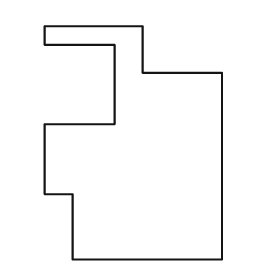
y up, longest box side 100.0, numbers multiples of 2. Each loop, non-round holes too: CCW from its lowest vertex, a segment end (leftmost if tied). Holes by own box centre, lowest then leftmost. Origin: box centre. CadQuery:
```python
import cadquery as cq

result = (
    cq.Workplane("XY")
    .moveTo(-26.0, -50.0)
    .lineTo(38.0, -50.0)
    .lineTo(38.0, 30.0)
    .lineTo(4.0, 30.0)
    .lineTo(4.0, 50.0)
    .lineTo(-38.0, 50.0)
    .lineTo(-38.0, 42.0)
    .lineTo(-8.0, 42.0)
    .lineTo(-8.0, 8.0)
    .lineTo(-38.0, 8.0)
    .lineTo(-38.0, -22.0)
    .lineTo(-26.0, -22.0)
    .close()
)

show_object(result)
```